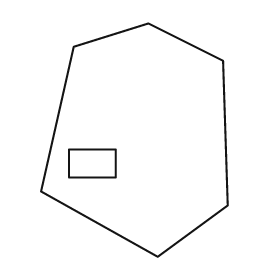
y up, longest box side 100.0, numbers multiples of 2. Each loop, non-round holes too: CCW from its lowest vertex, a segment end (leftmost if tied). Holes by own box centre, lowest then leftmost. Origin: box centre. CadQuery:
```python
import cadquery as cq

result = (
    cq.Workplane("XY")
    .moveTo(10.0, -50.0)
    .lineTo(40.0, -28.0)
    .lineTo(38.0, 34.0)
    .lineTo(6.0, 50.0)
    .lineTo(-26.0, 40.0)
    .lineTo(-40.0, -22.0)
    .close()
    .moveTo(-28.0, -16.0)
    .lineTo(-8.0, -16.0)
    .lineTo(-8.0, -4.0)
    .lineTo(-28.0, -4.0)
    .close()
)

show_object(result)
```